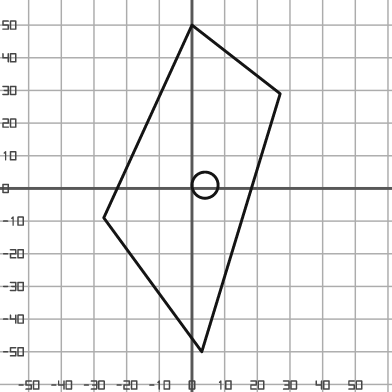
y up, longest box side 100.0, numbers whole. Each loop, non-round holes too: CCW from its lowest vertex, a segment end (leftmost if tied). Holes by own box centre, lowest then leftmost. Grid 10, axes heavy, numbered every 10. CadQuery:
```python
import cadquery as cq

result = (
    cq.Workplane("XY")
    .moveTo(3.0, -50.0)
    .lineTo(27.0, 29.0)
    .lineTo(0.0, 50.0)
    .lineTo(-27.0, -9.0)
    .close()
    .moveTo(4.0, 1.0)
    .circle(4.0)
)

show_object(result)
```